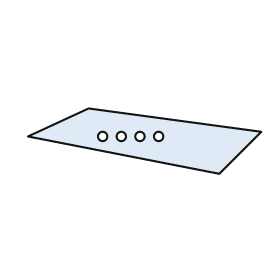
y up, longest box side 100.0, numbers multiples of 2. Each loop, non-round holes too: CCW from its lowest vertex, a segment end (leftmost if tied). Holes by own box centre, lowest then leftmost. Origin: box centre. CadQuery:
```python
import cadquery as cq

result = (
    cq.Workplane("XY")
    .moveTo(32.0, -14.0)
    .lineTo(50.0, 4.0)
    .lineTo(-24.0, 14.0)
    .lineTo(-50.0, 2.0)
    .close()
    .moveTo(-18.0, 2.0)
    .circle(2.0)
    .moveTo(-10.0, 2.0)
    .circle(2.0)
    .moveTo(-2.0, 2.0)
    .circle(2.0)
    .moveTo(6.0, 2.0)
    .circle(2.0)
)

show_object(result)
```